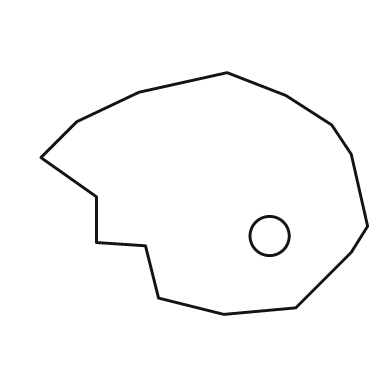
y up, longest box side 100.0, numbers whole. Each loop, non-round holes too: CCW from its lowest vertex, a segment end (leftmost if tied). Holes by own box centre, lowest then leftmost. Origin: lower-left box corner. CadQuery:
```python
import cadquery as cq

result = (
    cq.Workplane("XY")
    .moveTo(56.0, 0.0)
    .lineTo(78.0, 2.0)
    .lineTo(95.0, 19.0)
    .lineTo(100.0, 27.0)
    .lineTo(95.0, 49.0)
    .lineTo(89.0, 58.0)
    .lineTo(75.0, 67.0)
    .lineTo(57.0, 74.0)
    .lineTo(30.0, 68.0)
    .lineTo(11.0, 59.0)
    .lineTo(0.0, 48.0)
    .lineTo(17.0, 36.0)
    .lineTo(17.0, 22.0)
    .lineTo(32.0, 21.0)
    .lineTo(36.0, 5.0)
    .close()
    .moveTo(70.0, 24.0)
    .circle(6.0)
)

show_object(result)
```